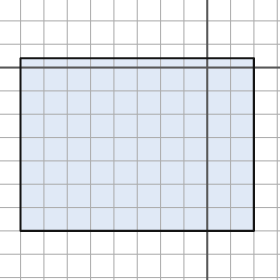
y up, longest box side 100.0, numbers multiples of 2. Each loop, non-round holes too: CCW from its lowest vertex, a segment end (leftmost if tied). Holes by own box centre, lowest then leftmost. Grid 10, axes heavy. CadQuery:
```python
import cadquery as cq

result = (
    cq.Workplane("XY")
    .moveTo(-80.0, -70.0)
    .lineTo(20.0, -70.0)
    .lineTo(20.0, 4.0)
    .lineTo(-80.0, 4.0)
    .close()
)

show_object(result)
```